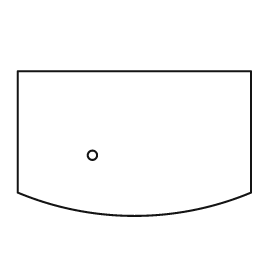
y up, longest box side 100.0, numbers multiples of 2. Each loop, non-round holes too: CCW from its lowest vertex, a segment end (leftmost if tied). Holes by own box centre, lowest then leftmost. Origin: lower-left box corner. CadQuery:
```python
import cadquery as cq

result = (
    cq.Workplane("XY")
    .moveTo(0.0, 10.0)
    .threePointArc((50.0, 0.0), (100.0, 10.0))
    .lineTo(100.0, 62.0)
    .lineTo(0.0, 62.0)
    .close()
    .moveTo(32.0, 26.0)
    .circle(2.0)
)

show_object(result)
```